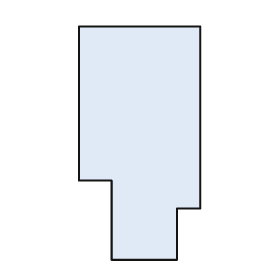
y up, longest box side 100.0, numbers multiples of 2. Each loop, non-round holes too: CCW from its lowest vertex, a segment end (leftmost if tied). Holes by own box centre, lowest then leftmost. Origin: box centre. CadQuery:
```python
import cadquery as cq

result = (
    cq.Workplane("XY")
    .moveTo(-12.0, -50.0)
    .lineTo(16.0, -50.0)
    .lineTo(16.0, -28.0)
    .lineTo(26.0, -28.0)
    .lineTo(26.0, 50.0)
    .lineTo(-26.0, 50.0)
    .lineTo(-26.0, -16.0)
    .lineTo(-12.0, -16.0)
    .close()
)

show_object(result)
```